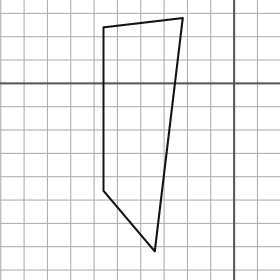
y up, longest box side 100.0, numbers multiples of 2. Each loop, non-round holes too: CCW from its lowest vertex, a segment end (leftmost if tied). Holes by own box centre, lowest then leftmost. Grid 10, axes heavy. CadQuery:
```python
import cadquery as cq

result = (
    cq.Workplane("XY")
    .moveTo(-34.0, -72.0)
    .lineTo(-22.0, 28.0)
    .lineTo(-56.0, 24.0)
    .lineTo(-56.0, -46.0)
    .close()
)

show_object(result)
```